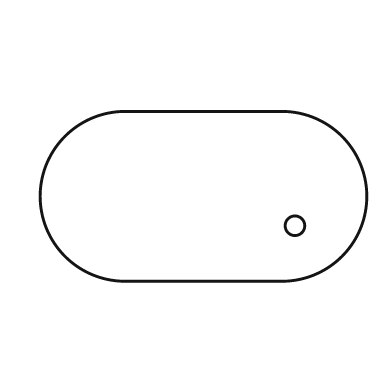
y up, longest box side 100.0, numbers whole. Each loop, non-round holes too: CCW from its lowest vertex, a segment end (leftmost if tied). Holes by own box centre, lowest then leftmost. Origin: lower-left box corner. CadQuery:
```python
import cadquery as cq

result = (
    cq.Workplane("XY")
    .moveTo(26.0, 0.0)
    .lineTo(74.0, 0.0)
    .threePointArc((100.0, 26.0), (74.0, 52.0))
    .lineTo(26.0, 52.0)
    .threePointArc((0.0, 26.0), (26.0, 0.0))
    .close()
    .moveTo(78.0, 17.0)
    .circle(3.0)
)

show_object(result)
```